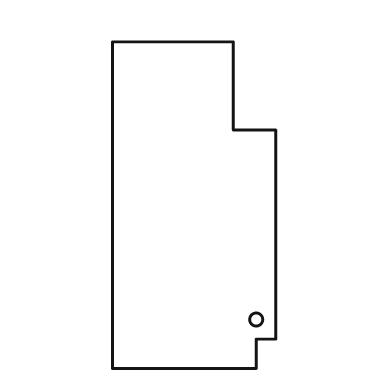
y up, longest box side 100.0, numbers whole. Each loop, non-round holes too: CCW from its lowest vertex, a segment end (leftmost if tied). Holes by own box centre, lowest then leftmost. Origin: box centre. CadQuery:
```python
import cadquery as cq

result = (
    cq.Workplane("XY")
    .moveTo(-25.0, -50.0)
    .lineTo(19.0, -50.0)
    .lineTo(19.0, -41.0)
    .lineTo(25.0, -41.0)
    .lineTo(25.0, 23.0)
    .lineTo(12.0, 23.0)
    .lineTo(12.0, 50.0)
    .lineTo(-25.0, 50.0)
    .close()
    .moveTo(19.0, -35.0)
    .circle(2.0)
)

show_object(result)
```